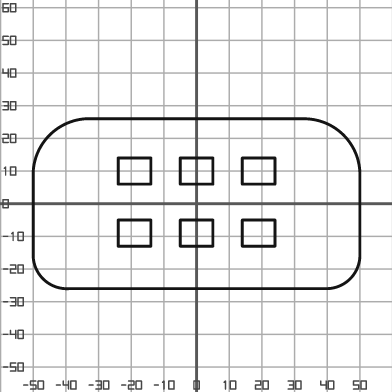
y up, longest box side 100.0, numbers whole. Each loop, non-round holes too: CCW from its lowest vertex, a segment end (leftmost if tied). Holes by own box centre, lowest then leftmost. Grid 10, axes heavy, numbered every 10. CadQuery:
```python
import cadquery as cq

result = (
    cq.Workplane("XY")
    .moveTo(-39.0, -26.0)
    .lineTo(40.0, -26.0)
    .threePointArc((47.0, -23.0), (50.0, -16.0))
    .lineTo(50.0, 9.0)
    .threePointArc((45.0, 21.0), (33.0, 26.0))
    .lineTo(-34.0, 26.0)
    .threePointArc((-45.0, 21.0), (-50.0, 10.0))
    .lineTo(-50.0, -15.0)
    .threePointArc((-47.0, -23.0), (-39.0, -26.0))
    .close()
    .moveTo(-24.0, -13.0)
    .lineTo(-14.0, -13.0)
    .lineTo(-14.0, -5.0)
    .lineTo(-24.0, -5.0)
    .close()
    .moveTo(-5.0, -13.0)
    .lineTo(5.0, -13.0)
    .lineTo(5.0, -5.0)
    .lineTo(-5.0, -5.0)
    .close()
    .moveTo(14.0, -13.0)
    .lineTo(24.0, -13.0)
    .lineTo(24.0, -5.0)
    .lineTo(14.0, -5.0)
    .close()
    .moveTo(-24.0, 6.0)
    .lineTo(-14.0, 6.0)
    .lineTo(-14.0, 14.0)
    .lineTo(-24.0, 14.0)
    .close()
    .moveTo(-5.0, 6.0)
    .lineTo(5.0, 6.0)
    .lineTo(5.0, 14.0)
    .lineTo(-5.0, 14.0)
    .close()
    .moveTo(14.0, 6.0)
    .lineTo(24.0, 6.0)
    .lineTo(24.0, 14.0)
    .lineTo(14.0, 14.0)
    .close()
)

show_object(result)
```